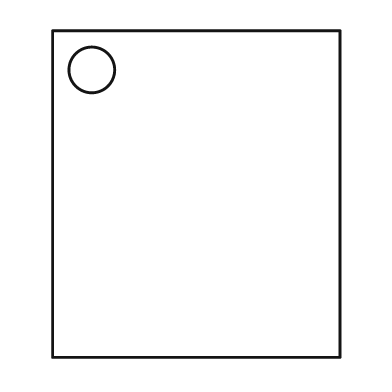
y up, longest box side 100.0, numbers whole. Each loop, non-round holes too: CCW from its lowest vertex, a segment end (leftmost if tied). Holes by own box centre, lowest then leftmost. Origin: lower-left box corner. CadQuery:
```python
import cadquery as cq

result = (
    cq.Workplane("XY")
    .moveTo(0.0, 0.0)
    .lineTo(88.0, 0.0)
    .lineTo(88.0, 100.0)
    .lineTo(0.0, 100.0)
    .close()
    .moveTo(12.0, 88.0)
    .circle(7.0)
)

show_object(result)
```